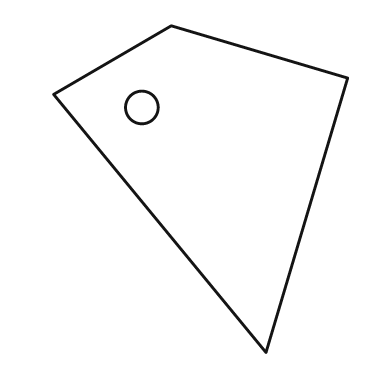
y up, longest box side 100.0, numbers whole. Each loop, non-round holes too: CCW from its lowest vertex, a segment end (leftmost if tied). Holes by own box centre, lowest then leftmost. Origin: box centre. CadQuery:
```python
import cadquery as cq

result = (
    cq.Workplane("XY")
    .moveTo(20.0, -50.0)
    .lineTo(45.0, 34.0)
    .lineTo(-9.0, 50.0)
    .lineTo(-45.0, 29.0)
    .close()
    .moveTo(-18.0, 25.0)
    .circle(5.0)
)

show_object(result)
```